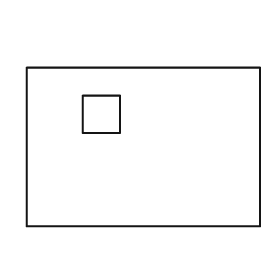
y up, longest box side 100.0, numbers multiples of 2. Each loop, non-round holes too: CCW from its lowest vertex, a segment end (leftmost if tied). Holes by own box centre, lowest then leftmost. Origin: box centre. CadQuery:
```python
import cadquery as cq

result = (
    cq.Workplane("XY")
    .moveTo(-50.0, -34.0)
    .lineTo(50.0, -34.0)
    .lineTo(50.0, 34.0)
    .lineTo(-50.0, 34.0)
    .close()
    .moveTo(-26.0, 6.0)
    .lineTo(-10.0, 6.0)
    .lineTo(-10.0, 22.0)
    .lineTo(-26.0, 22.0)
    .close()
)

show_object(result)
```